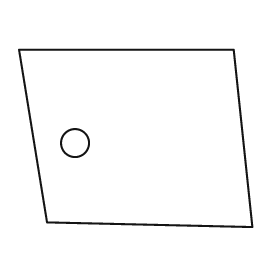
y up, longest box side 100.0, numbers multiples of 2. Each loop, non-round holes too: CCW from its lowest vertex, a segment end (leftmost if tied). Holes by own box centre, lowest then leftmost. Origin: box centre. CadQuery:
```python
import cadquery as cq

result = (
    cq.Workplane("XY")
    .moveTo(50.0, -38.0)
    .lineTo(42.0, 38.0)
    .lineTo(-50.0, 38.0)
    .lineTo(-38.0, -36.0)
    .close()
    .moveTo(-26.0, -2.0)
    .circle(6.0)
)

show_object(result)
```